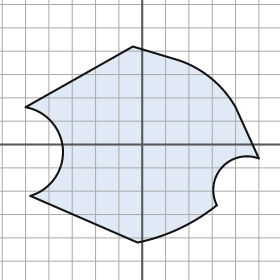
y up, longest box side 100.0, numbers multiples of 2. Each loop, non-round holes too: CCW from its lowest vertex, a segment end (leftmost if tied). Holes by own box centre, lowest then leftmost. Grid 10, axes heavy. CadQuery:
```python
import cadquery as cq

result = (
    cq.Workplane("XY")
    .moveTo(-2.0, -42.0)
    .threePointArc((16.0, -36.0), (32.0, -26.0))
    .threePointArc((34.0, -10.0), (50.0, -6.0))
    .lineTo(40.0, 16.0)
    .threePointArc((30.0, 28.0), (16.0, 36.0))
    .lineTo(-4.0, 42.0)
    .lineTo(-50.0, 16.0)
    .threePointArc((-34.0, -2.0), (-48.0, -22.0))
    .close()
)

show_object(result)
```